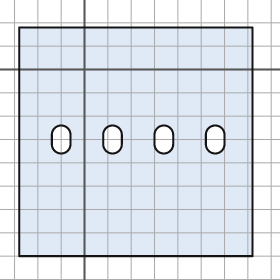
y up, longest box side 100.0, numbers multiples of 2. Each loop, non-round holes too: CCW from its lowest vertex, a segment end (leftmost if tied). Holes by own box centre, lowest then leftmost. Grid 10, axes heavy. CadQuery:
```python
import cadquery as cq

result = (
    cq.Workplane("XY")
    .moveTo(-28.0, -80.0)
    .lineTo(72.0, -80.0)
    .lineTo(72.0, 18.0)
    .lineTo(-28.0, 18.0)
    .close()
    .moveTo(-14.0, -32.0)
    .threePointArc((-10.0, -36.0), (-6.0, -32.0))
    .lineTo(-6.0, -28.0)
    .threePointArc((-10.0, -24.0), (-14.0, -28.0))
    .close()
    .moveTo(8.0, -32.0)
    .threePointArc((12.0, -36.0), (16.0, -32.0))
    .lineTo(16.0, -28.0)
    .threePointArc((12.0, -24.0), (8.0, -28.0))
    .close()
    .moveTo(30.0, -32.0)
    .threePointArc((34.0, -36.0), (38.0, -32.0))
    .lineTo(38.0, -28.0)
    .threePointArc((34.0, -24.0), (30.0, -28.0))
    .close()
    .moveTo(52.0, -32.0)
    .threePointArc((56.0, -36.0), (60.0, -32.0))
    .lineTo(60.0, -28.0)
    .threePointArc((56.0, -24.0), (52.0, -28.0))
    .close()
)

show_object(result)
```